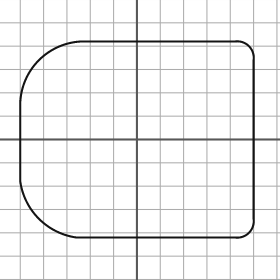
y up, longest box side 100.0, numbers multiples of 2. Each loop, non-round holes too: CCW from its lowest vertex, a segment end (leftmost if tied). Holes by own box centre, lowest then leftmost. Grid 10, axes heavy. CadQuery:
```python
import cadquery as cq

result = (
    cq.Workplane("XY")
    .moveTo(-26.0, -42.0)
    .lineTo(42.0, -42.0)
    .threePointArc((48.0, -40.0), (50.0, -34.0))
    .lineTo(50.0, 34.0)
    .threePointArc((48.0, 40.0), (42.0, 42.0))
    .lineTo(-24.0, 42.0)
    .threePointArc((-42.0, 34.0), (-50.0, 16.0))
    .lineTo(-50.0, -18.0)
    .threePointArc((-42.0, -34.0), (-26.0, -42.0))
    .close()
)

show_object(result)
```